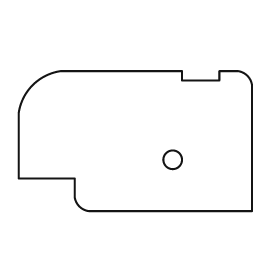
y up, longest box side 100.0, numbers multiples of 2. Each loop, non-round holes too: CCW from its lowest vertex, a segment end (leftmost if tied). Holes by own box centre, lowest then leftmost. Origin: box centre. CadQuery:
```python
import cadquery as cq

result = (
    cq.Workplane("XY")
    .moveTo(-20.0, -30.0)
    .lineTo(50.0, -30.0)
    .lineTo(50.0, 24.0)
    .threePointArc((48.0, 28.0), (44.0, 30.0))
    .lineTo(36.0, 30.0)
    .lineTo(36.0, 26.0)
    .lineTo(20.0, 26.0)
    .lineTo(20.0, 30.0)
    .lineTo(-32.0, 30.0)
    .threePointArc((-44.0, 24.0), (-50.0, 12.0))
    .lineTo(-50.0, -16.0)
    .lineTo(-26.0, -16.0)
    .lineTo(-26.0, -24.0)
    .threePointArc((-24.0, -28.0), (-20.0, -30.0))
    .close()
    .moveTo(16.0, -8.0)
    .circle(4.0)
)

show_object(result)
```